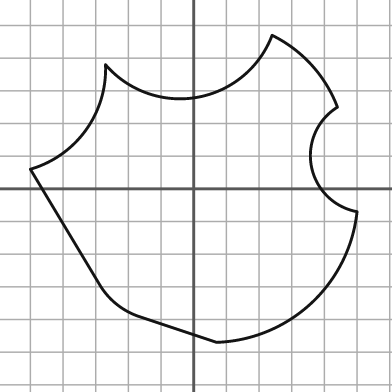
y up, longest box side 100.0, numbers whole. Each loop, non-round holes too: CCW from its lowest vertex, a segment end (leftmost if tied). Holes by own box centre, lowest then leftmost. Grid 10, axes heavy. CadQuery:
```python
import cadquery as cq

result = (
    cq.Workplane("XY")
    .moveTo(7.0, -47.0)
    .threePointArc((36.0, -35.0), (50.0, -7.0))
    .threePointArc((36.0, 7.0), (44.0, 25.0))
    .threePointArc((36.0, 38.0), (24.0, 47.0))
    .threePointArc((1.0, 28.0), (-27.0, 38.0))
    .threePointArc((-33.0, 18.0), (-50.0, 6.0))
    .lineTo(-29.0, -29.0)
    .threePointArc((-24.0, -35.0), (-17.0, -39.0))
    .close()
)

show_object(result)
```